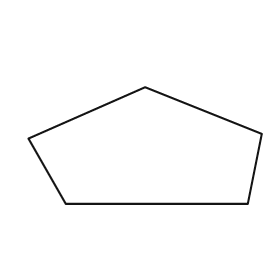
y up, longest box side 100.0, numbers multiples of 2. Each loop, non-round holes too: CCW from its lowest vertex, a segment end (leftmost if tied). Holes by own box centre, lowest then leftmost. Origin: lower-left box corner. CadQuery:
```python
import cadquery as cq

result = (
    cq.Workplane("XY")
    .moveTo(16.0, 0.0)
    .lineTo(94.0, 0.0)
    .lineTo(100.0, 30.0)
    .lineTo(50.0, 50.0)
    .lineTo(0.0, 28.0)
    .close()
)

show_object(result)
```